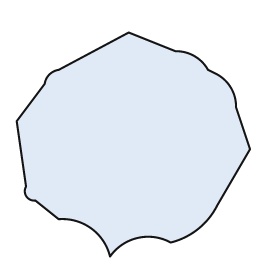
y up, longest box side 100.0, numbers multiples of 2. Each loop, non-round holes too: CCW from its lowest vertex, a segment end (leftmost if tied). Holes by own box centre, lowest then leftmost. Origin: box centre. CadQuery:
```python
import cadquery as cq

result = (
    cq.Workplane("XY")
    .moveTo(-10.0, -48.0)
    .threePointArc((2.0, -40.0), (16.0, -42.0))
    .threePointArc((28.0, -36.0), (36.0, -26.0))
    .lineTo(50.0, -2.0)
    .lineTo(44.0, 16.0)
    .threePointArc((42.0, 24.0), (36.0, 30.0))
    .lineTo(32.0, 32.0)
    .threePointArc((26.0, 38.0), (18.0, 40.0))
    .lineTo(-2.0, 48.0)
    .lineTo(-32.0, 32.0)
    .threePointArc((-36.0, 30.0), (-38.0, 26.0))
    .lineTo(-50.0, 10.0)
    .lineTo(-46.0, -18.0)
    .threePointArc((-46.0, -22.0), (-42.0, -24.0))
    .lineTo(-32.0, -32.0)
    .threePointArc((-18.0, -36.0), (-10.0, -48.0))
    .close()
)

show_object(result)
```